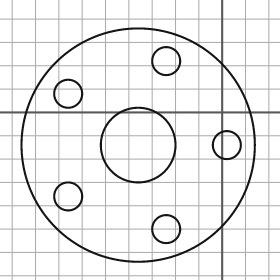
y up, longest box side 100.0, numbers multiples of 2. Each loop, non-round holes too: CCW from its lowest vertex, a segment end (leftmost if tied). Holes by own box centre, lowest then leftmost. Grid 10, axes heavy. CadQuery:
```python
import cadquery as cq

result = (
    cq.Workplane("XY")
    .moveTo(-36.0, -14.0)
    .circle(50.0)
    .moveTo(-24.0, -50.0)
    .circle(6.0)
    .moveTo(-66.0, -36.0)
    .circle(6.0)
    .moveTo(-36.0, -14.0)
    .circle(16.0)
    .moveTo(2.0, -14.0)
    .circle(6.0)
    .moveTo(-66.0, 8.0)
    .circle(6.0)
    .moveTo(-24.0, 22.0)
    .circle(6.0)
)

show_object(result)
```